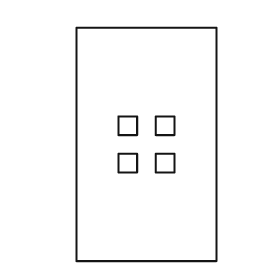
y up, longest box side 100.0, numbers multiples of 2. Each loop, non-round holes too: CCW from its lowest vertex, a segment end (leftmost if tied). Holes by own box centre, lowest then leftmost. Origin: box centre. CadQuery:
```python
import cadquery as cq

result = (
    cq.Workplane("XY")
    .moveTo(-30.0, -50.0)
    .lineTo(30.0, -50.0)
    .lineTo(30.0, 50.0)
    .lineTo(-30.0, 50.0)
    .close()
    .moveTo(-12.0, -12.0)
    .lineTo(-4.0, -12.0)
    .lineTo(-4.0, -4.0)
    .lineTo(-12.0, -4.0)
    .close()
    .moveTo(4.0, -12.0)
    .lineTo(12.0, -12.0)
    .lineTo(12.0, -4.0)
    .lineTo(4.0, -4.0)
    .close()
    .moveTo(-12.0, 4.0)
    .lineTo(-4.0, 4.0)
    .lineTo(-4.0, 12.0)
    .lineTo(-12.0, 12.0)
    .close()
    .moveTo(4.0, 4.0)
    .lineTo(12.0, 4.0)
    .lineTo(12.0, 12.0)
    .lineTo(4.0, 12.0)
    .close()
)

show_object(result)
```